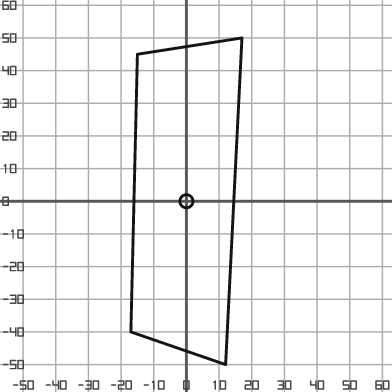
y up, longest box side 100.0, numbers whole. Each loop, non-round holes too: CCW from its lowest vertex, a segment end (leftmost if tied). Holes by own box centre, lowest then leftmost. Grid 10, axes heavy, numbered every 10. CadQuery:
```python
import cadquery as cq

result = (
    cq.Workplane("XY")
    .moveTo(12.0, -50.0)
    .lineTo(17.0, 50.0)
    .lineTo(-15.0, 45.0)
    .lineTo(-17.0, -40.0)
    .close()
    .moveTo(0.0, 0.0)
    .circle(2.0)
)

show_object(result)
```